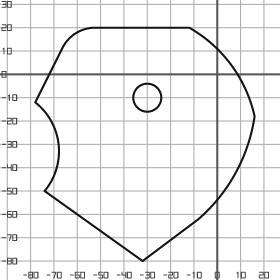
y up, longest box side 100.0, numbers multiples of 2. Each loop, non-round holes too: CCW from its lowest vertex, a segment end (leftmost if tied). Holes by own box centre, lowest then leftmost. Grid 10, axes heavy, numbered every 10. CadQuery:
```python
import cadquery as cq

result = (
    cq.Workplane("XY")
    .moveTo(-32.0, -80.0)
    .lineTo(-8.0, -62.0)
    .threePointArc((8.0, -42.0), (16.0, -18.0))
    .threePointArc((6.0, 4.0), (-12.0, 20.0))
    .lineTo(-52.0, 20.0)
    .threePointArc((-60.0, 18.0), (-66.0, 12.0))
    .lineTo(-78.0, -12.0)
    .threePointArc((-68.0, -30.0), (-74.0, -50.0))
    .close()
    .moveTo(-30.0, -10.0)
    .circle(6.0)
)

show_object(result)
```